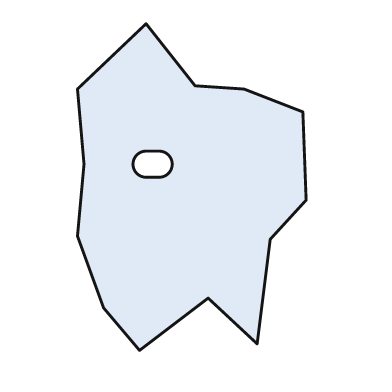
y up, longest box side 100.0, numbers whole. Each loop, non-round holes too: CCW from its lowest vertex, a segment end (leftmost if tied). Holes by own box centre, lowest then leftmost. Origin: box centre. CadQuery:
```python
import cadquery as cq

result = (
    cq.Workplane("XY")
    .moveTo(-16.0, -50.0)
    .lineTo(5.0, -34.0)
    .lineTo(20.0, -48.0)
    .lineTo(24.0, -16.0)
    .lineTo(35.0, -4.0)
    .lineTo(34.0, 23.0)
    .lineTo(16.0, 30.0)
    .lineTo(1.0, 31.0)
    .lineTo(-14.0, 50.0)
    .lineTo(-35.0, 30.0)
    .lineTo(-33.0, 7.0)
    .lineTo(-35.0, -15.0)
    .lineTo(-27.0, -37.0)
    .close()
    .moveTo(-14.0, 3.0)
    .lineTo(-10.0, 3.0)
    .threePointArc((-6.0, 7.0), (-10.0, 11.0))
    .lineTo(-14.0, 11.0)
    .threePointArc((-18.0, 7.0), (-14.0, 3.0))
    .close()
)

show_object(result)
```